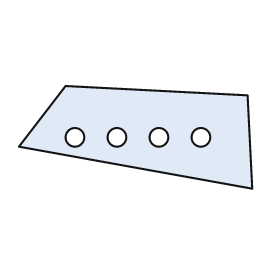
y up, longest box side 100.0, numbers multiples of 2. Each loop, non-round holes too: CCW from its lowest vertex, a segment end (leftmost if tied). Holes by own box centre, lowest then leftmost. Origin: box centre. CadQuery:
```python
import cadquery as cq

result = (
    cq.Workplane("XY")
    .moveTo(50.0, -22.0)
    .lineTo(48.0, 18.0)
    .lineTo(-30.0, 22.0)
    .lineTo(-50.0, -4.0)
    .close()
    .moveTo(-26.0, 0.0)
    .circle(4.0)
    .moveTo(-8.0, 0.0)
    .circle(4.0)
    .moveTo(10.0, 0.0)
    .circle(4.0)
    .moveTo(28.0, 0.0)
    .circle(4.0)
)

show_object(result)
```